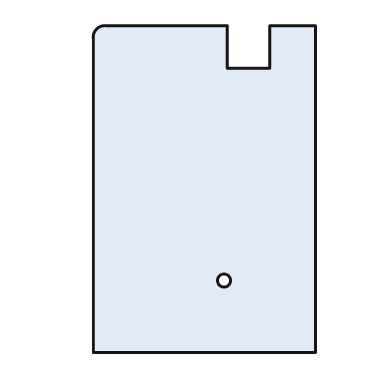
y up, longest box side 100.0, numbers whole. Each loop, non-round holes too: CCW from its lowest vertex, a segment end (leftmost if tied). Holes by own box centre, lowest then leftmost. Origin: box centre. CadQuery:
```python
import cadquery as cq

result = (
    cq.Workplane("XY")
    .moveTo(-34.0, -50.0)
    .lineTo(34.0, -50.0)
    .lineTo(34.0, 50.0)
    .lineTo(20.0, 50.0)
    .lineTo(20.0, 37.0)
    .lineTo(7.0, 37.0)
    .lineTo(7.0, 50.0)
    .lineTo(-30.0, 50.0)
    .threePointArc((-33.0, 49.0), (-34.0, 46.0))
    .close()
    .moveTo(6.0, -28.0)
    .circle(2.0)
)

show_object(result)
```